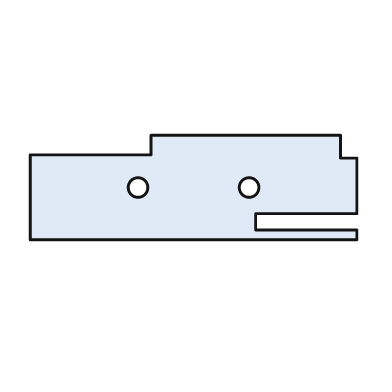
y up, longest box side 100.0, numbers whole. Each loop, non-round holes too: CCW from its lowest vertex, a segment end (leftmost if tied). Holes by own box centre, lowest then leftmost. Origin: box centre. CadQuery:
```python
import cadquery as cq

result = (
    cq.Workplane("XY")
    .moveTo(-50.0, -16.0)
    .lineTo(50.0, -16.0)
    .lineTo(50.0, -13.0)
    .lineTo(19.0, -13.0)
    .lineTo(19.0, -8.0)
    .lineTo(50.0, -8.0)
    .lineTo(50.0, 9.0)
    .lineTo(45.0, 9.0)
    .lineTo(45.0, 16.0)
    .lineTo(-13.0, 16.0)
    .lineTo(-13.0, 10.0)
    .lineTo(-50.0, 10.0)
    .close()
    .moveTo(-17.0, 0.0)
    .circle(3.0)
    .moveTo(17.0, 0.0)
    .circle(3.0)
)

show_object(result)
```